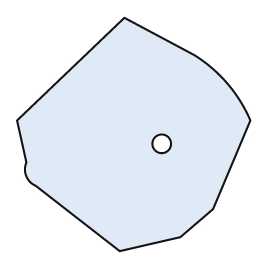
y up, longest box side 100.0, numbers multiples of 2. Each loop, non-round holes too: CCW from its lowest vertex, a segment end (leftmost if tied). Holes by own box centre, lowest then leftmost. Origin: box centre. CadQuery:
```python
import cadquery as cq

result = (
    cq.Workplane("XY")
    .moveTo(-6.0, -50.0)
    .lineTo(20.0, -44.0)
    .lineTo(34.0, -32.0)
    .lineTo(50.0, 6.0)
    .threePointArc((40.0, 22.0), (26.0, 34.0))
    .lineTo(-4.0, 50.0)
    .lineTo(-50.0, 6.0)
    .lineTo(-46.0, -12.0)
    .threePointArc((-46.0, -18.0), (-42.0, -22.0))
    .close()
    .moveTo(12.0, -4.0)
    .circle(4.0)
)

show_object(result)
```